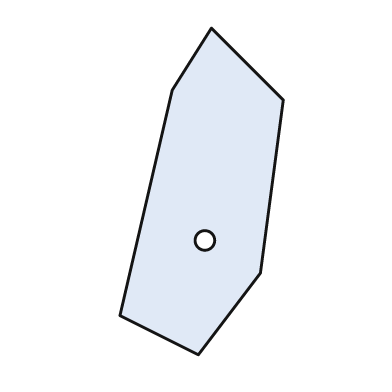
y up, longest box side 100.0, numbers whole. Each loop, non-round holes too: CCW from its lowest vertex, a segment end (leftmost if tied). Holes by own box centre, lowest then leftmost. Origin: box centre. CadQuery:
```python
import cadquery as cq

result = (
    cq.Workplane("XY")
    .moveTo(-1.0, -50.0)
    .lineTo(18.0, -25.0)
    .lineTo(25.0, 28.0)
    .lineTo(3.0, 50.0)
    .lineTo(-9.0, 31.0)
    .lineTo(-25.0, -38.0)
    .close()
    .moveTo(1.0, -15.0)
    .circle(3.0)
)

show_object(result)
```